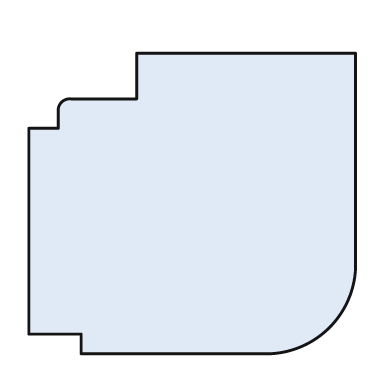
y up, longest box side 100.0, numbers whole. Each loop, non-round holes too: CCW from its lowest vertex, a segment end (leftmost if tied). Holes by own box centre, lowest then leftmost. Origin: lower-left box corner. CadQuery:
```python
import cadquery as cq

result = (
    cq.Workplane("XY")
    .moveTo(16.0, 0.0)
    .lineTo(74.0, 0.0)
    .threePointArc((92.0, 8.0), (100.0, 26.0))
    .lineTo(100.0, 92.0)
    .lineTo(33.0, 92.0)
    .lineTo(33.0, 78.0)
    .lineTo(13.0, 78.0)
    .threePointArc((10.0, 77.0), (9.0, 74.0))
    .lineTo(9.0, 69.0)
    .lineTo(0.0, 69.0)
    .lineTo(0.0, 6.0)
    .lineTo(16.0, 6.0)
    .close()
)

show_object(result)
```